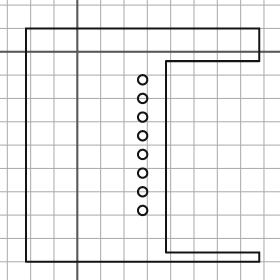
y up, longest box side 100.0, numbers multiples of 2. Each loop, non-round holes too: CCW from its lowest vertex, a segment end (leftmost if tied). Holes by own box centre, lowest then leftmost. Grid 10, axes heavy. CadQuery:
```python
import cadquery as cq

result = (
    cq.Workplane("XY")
    .moveTo(-22.0, -90.0)
    .lineTo(78.0, -90.0)
    .lineTo(78.0, -86.0)
    .lineTo(38.0, -86.0)
    .lineTo(38.0, -4.0)
    .lineTo(78.0, -4.0)
    .lineTo(78.0, 10.0)
    .lineTo(-22.0, 10.0)
    .close()
    .moveTo(28.0, -68.0)
    .circle(2.0)
    .moveTo(28.0, -60.0)
    .circle(2.0)
    .moveTo(28.0, -52.0)
    .circle(2.0)
    .moveTo(28.0, -44.0)
    .circle(2.0)
    .moveTo(28.0, -36.0)
    .circle(2.0)
    .moveTo(28.0, -28.0)
    .circle(2.0)
    .moveTo(28.0, -20.0)
    .circle(2.0)
    .moveTo(28.0, -12.0)
    .circle(2.0)
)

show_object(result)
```